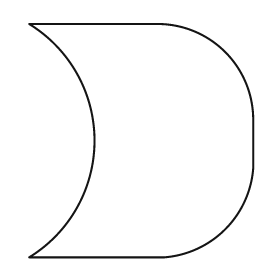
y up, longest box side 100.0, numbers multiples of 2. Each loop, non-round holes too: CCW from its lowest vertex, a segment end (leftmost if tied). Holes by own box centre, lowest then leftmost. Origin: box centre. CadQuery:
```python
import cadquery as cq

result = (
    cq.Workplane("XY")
    .moveTo(-48.0, -50.0)
    .lineTo(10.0, -50.0)
    .threePointArc((36.0, -38.0), (48.0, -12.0))
    .lineTo(48.0, 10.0)
    .threePointArc((36.0, 38.0), (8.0, 50.0))
    .lineTo(-48.0, 50.0)
    .threePointArc((-20.0, 0.0), (-48.0, -50.0))
    .close()
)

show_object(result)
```